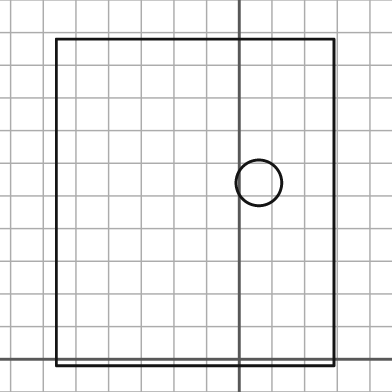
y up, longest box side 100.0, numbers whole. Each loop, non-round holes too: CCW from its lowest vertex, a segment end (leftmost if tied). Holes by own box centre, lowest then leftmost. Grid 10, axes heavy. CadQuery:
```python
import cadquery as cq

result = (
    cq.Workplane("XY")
    .moveTo(-56.0, -2.0)
    .lineTo(29.0, -2.0)
    .lineTo(29.0, 98.0)
    .lineTo(-56.0, 98.0)
    .close()
    .moveTo(6.0, 54.0)
    .circle(7.0)
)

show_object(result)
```